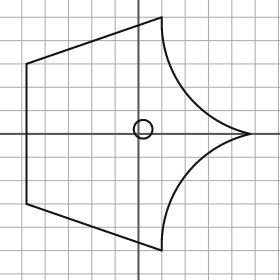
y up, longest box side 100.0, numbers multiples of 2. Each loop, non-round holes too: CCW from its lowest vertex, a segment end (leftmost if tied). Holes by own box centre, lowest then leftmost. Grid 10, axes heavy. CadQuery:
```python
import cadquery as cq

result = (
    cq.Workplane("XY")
    .moveTo(10.0, -50.0)
    .threePointArc((20.0, -18.0), (48.0, 0.0))
    .threePointArc((20.0, 18.0), (10.0, 50.0))
    .lineTo(-48.0, 30.0)
    .lineTo(-48.0, -30.0)
    .close()
    .moveTo(2.0, 2.0)
    .circle(4.0)
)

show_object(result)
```